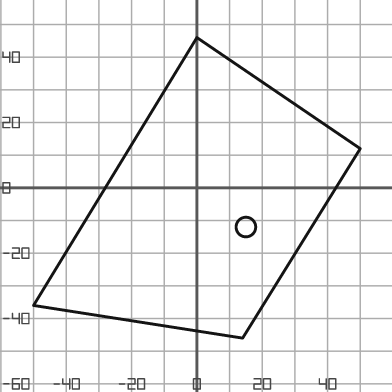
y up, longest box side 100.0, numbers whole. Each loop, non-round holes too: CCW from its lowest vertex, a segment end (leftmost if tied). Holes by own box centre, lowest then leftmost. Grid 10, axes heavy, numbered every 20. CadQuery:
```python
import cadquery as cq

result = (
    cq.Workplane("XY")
    .moveTo(14.0, -46.0)
    .lineTo(50.0, 12.0)
    .lineTo(0.0, 46.0)
    .lineTo(-50.0, -36.0)
    .close()
    .moveTo(15.0, -12.0)
    .circle(3.0)
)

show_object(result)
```